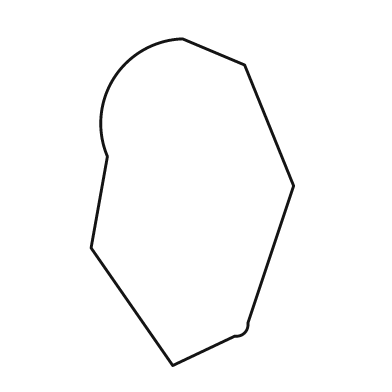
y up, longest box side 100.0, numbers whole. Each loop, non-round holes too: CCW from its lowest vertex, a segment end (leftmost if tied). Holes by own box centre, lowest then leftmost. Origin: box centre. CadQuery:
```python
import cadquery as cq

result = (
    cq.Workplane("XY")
    .moveTo(-6.0, -50.0)
    .lineTo(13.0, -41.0)
    .threePointArc((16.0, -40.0), (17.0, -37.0))
    .lineTo(31.0, 5.0)
    .lineTo(16.0, 42.0)
    .lineTo(-3.0, 50.0)
    .threePointArc((-24.0, 38.0), (-26.0, 14.0))
    .lineTo(-31.0, -14.0)
    .close()
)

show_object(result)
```